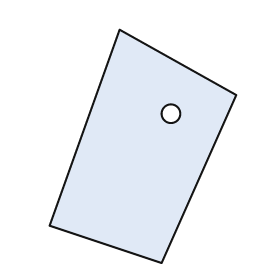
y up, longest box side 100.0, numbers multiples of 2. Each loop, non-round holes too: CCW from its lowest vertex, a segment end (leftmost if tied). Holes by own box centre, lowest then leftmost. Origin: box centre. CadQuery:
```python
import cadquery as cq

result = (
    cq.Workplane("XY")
    .moveTo(8.0, -50.0)
    .lineTo(40.0, 22.0)
    .lineTo(-10.0, 50.0)
    .lineTo(-40.0, -34.0)
    .close()
    .moveTo(12.0, 14.0)
    .circle(4.0)
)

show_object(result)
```